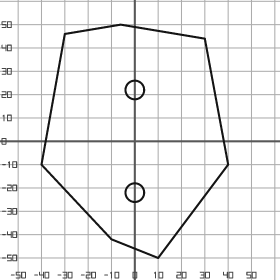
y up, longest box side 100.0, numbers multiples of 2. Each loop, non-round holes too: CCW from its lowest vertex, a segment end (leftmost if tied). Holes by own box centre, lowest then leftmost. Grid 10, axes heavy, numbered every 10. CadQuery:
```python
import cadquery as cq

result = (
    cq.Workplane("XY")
    .moveTo(10.0, -50.0)
    .lineTo(40.0, -10.0)
    .lineTo(30.0, 44.0)
    .lineTo(-6.0, 50.0)
    .lineTo(-30.0, 46.0)
    .lineTo(-40.0, -10.0)
    .lineTo(-10.0, -42.0)
    .close()
    .moveTo(0.0, -22.0)
    .circle(4.0)
    .moveTo(0.0, 22.0)
    .circle(4.0)
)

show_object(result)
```